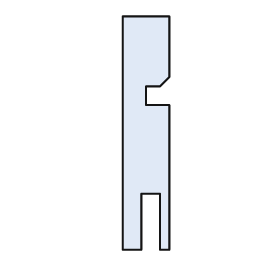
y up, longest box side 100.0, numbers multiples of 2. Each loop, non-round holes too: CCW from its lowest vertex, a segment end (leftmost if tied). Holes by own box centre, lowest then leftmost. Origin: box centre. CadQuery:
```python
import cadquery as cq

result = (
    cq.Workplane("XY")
    .moveTo(-10.0, -50.0)
    .lineTo(-2.0, -50.0)
    .lineTo(-2.0, -26.0)
    .lineTo(6.0, -26.0)
    .lineTo(6.0, -50.0)
    .lineTo(10.0, -50.0)
    .lineTo(10.0, 12.0)
    .lineTo(0.0, 12.0)
    .lineTo(0.0, 20.0)
    .lineTo(6.0, 20.0)
    .lineTo(10.0, 24.0)
    .lineTo(10.0, 50.0)
    .lineTo(-10.0, 50.0)
    .close()
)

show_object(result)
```